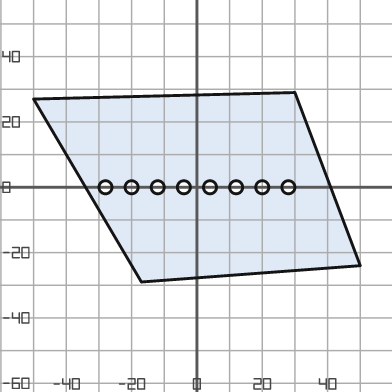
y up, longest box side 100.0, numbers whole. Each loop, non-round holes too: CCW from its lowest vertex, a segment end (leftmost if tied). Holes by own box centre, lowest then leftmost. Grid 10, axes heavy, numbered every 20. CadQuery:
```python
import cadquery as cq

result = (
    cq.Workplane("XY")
    .moveTo(-17.0, -29.0)
    .lineTo(50.0, -24.0)
    .lineTo(30.0, 29.0)
    .lineTo(-50.0, 27.0)
    .close()
    .moveTo(-28.0, 0.0)
    .circle(2.0)
    .moveTo(-20.0, 0.0)
    .circle(2.0)
    .moveTo(-12.0, 0.0)
    .circle(2.0)
    .moveTo(-4.0, 0.0)
    .circle(2.0)
    .moveTo(4.0, 0.0)
    .circle(2.0)
    .moveTo(12.0, 0.0)
    .circle(2.0)
    .moveTo(20.0, 0.0)
    .circle(2.0)
    .moveTo(28.0, 0.0)
    .circle(2.0)
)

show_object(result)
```